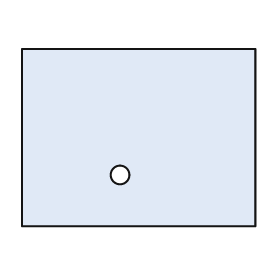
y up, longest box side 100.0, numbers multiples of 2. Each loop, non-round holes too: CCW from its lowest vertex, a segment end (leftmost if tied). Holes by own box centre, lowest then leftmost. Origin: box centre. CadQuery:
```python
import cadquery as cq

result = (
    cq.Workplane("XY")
    .moveTo(-50.0, -38.0)
    .lineTo(50.0, -38.0)
    .lineTo(50.0, 38.0)
    .lineTo(-50.0, 38.0)
    .close()
    .moveTo(-8.0, -16.0)
    .circle(4.0)
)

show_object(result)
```